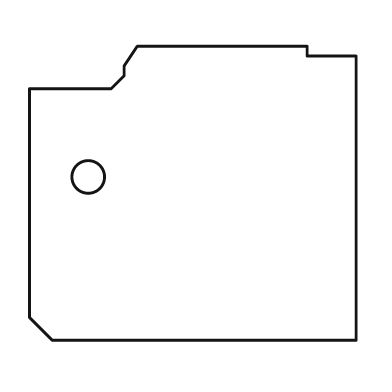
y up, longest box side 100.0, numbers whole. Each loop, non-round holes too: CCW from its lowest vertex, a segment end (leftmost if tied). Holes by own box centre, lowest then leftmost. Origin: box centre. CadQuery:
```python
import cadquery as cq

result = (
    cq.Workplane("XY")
    .moveTo(-43.0, -45.0)
    .lineTo(50.0, -45.0)
    .lineTo(50.0, 42.0)
    .lineTo(35.0, 42.0)
    .lineTo(35.0, 45.0)
    .lineTo(-17.0, 45.0)
    .lineTo(-21.0, 39.0)
    .lineTo(-21.0, 36.0)
    .lineTo(-25.0, 32.0)
    .lineTo(-50.0, 32.0)
    .lineTo(-50.0, -38.0)
    .close()
    .moveTo(-32.0, 5.0)
    .circle(5.0)
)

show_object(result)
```